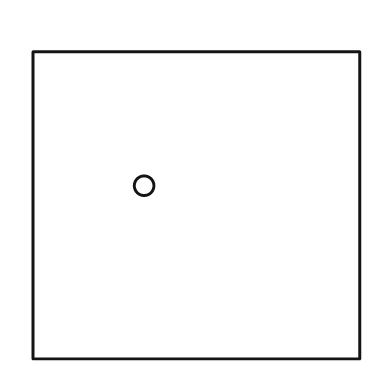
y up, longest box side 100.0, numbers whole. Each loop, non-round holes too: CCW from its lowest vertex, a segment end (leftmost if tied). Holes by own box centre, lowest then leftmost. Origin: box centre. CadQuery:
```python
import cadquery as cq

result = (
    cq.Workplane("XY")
    .moveTo(-50.0, -47.0)
    .lineTo(50.0, -47.0)
    .lineTo(50.0, 47.0)
    .lineTo(-50.0, 47.0)
    .close()
    .moveTo(-16.0, 6.0)
    .circle(3.0)
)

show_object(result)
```